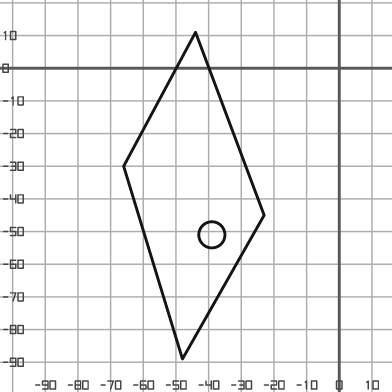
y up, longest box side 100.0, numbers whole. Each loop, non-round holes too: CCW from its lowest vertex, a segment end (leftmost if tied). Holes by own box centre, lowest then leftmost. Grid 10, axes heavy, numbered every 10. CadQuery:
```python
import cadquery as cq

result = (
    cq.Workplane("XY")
    .moveTo(-48.0, -89.0)
    .lineTo(-23.0, -45.0)
    .lineTo(-44.0, 11.0)
    .lineTo(-66.0, -30.0)
    .close()
    .moveTo(-39.0, -51.0)
    .circle(4.0)
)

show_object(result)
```